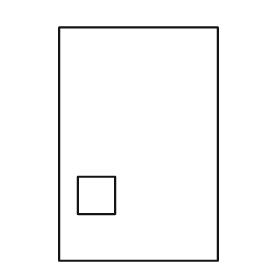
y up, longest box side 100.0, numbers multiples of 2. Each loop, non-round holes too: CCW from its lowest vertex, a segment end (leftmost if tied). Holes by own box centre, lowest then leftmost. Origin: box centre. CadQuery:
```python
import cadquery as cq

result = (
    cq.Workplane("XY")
    .moveTo(-34.0, -50.0)
    .lineTo(34.0, -50.0)
    .lineTo(34.0, 50.0)
    .lineTo(-34.0, 50.0)
    .close()
    .moveTo(-26.0, -30.0)
    .lineTo(-10.0, -30.0)
    .lineTo(-10.0, -14.0)
    .lineTo(-26.0, -14.0)
    .close()
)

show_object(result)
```